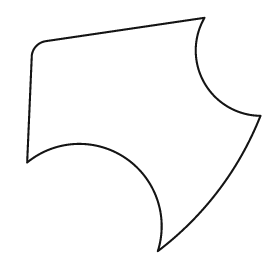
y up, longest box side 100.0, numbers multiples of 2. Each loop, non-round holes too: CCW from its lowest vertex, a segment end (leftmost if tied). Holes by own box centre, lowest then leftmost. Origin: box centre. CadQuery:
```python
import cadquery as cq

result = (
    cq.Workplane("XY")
    .moveTo(6.0, -50.0)
    .threePointArc((32.0, -24.0), (50.0, 8.0))
    .threePointArc((26.0, 22.0), (26.0, 50.0))
    .lineTo(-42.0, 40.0)
    .threePointArc((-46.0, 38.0), (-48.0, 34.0))
    .lineTo(-50.0, -12.0)
    .threePointArc((-8.0, -10.0), (6.0, -50.0))
    .close()
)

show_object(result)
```